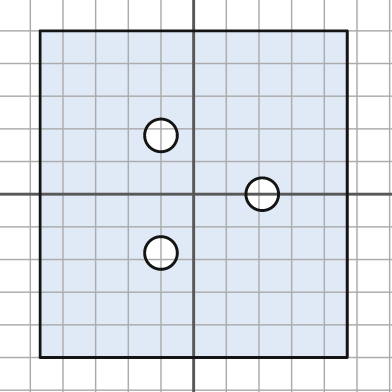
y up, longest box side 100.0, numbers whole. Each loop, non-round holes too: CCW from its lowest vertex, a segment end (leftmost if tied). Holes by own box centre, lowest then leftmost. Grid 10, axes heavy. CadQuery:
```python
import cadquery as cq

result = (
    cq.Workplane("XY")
    .moveTo(-47.0, -50.0)
    .lineTo(47.0, -50.0)
    .lineTo(47.0, 50.0)
    .lineTo(-47.0, 50.0)
    .close()
    .moveTo(-10.0, -18.0)
    .circle(5.0)
    .moveTo(21.0, 0.0)
    .circle(5.0)
    .moveTo(-10.0, 18.0)
    .circle(5.0)
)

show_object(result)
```